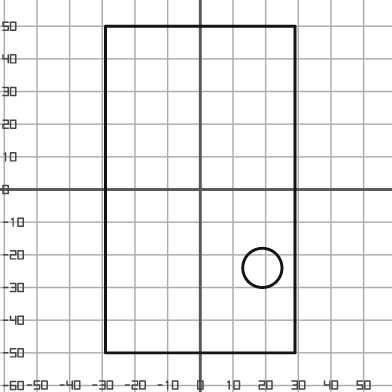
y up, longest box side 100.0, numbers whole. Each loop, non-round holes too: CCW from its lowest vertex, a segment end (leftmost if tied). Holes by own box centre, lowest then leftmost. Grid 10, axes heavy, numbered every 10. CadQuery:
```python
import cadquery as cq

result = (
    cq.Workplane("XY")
    .moveTo(-29.0, -50.0)
    .lineTo(29.0, -50.0)
    .lineTo(29.0, 50.0)
    .lineTo(-29.0, 50.0)
    .close()
    .moveTo(19.0, -24.0)
    .circle(6.0)
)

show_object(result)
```